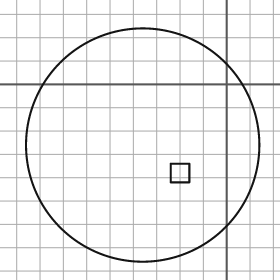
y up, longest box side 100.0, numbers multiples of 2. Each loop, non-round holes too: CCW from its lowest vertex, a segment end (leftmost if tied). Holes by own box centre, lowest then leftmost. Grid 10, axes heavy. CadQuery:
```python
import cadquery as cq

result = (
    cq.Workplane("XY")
    .moveTo(-36.0, -26.0)
    .circle(50.0)
    .moveTo(-24.0, -42.0)
    .lineTo(-16.0, -42.0)
    .lineTo(-16.0, -34.0)
    .lineTo(-24.0, -34.0)
    .close()
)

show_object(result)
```